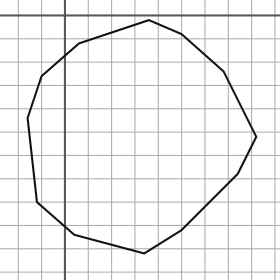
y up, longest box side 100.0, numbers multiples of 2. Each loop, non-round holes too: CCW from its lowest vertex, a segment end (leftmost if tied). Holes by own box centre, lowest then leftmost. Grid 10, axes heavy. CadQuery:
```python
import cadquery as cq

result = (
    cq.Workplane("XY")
    .moveTo(34.0, -102.0)
    .lineTo(50.0, -92.0)
    .lineTo(74.0, -68.0)
    .lineTo(82.0, -52.0)
    .lineTo(68.0, -24.0)
    .lineTo(50.0, -8.0)
    .lineTo(36.0, -2.0)
    .lineTo(6.0, -12.0)
    .lineTo(-10.0, -26.0)
    .lineTo(-16.0, -44.0)
    .lineTo(-12.0, -80.0)
    .lineTo(4.0, -94.0)
    .close()
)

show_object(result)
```